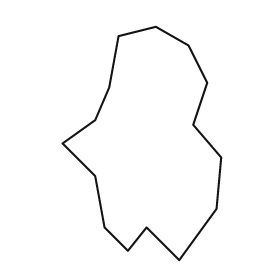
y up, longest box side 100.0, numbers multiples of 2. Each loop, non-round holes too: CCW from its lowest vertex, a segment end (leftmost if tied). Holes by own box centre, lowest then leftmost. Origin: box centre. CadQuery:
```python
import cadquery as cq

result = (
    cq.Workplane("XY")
    .moveTo(16.0, -50.0)
    .lineTo(32.0, -28.0)
    .lineTo(34.0, -6.0)
    .lineTo(22.0, 8.0)
    .lineTo(28.0, 26.0)
    .lineTo(20.0, 42.0)
    .lineTo(6.0, 50.0)
    .lineTo(-10.0, 46.0)
    .lineTo(-14.0, 24.0)
    .lineTo(-20.0, 10.0)
    .lineTo(-34.0, 0.0)
    .lineTo(-20.0, -14.0)
    .lineTo(-16.0, -36.0)
    .lineTo(-6.0, -46.0)
    .lineTo(2.0, -36.0)
    .close()
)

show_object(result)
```